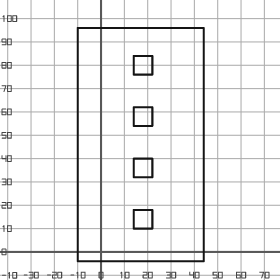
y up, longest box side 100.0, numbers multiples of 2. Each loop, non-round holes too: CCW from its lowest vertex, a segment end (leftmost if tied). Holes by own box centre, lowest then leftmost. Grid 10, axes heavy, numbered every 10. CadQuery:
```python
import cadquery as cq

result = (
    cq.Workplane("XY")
    .moveTo(-10.0, -4.0)
    .lineTo(44.0, -4.0)
    .lineTo(44.0, 96.0)
    .lineTo(-10.0, 96.0)
    .close()
    .moveTo(14.0, 10.0)
    .lineTo(22.0, 10.0)
    .lineTo(22.0, 18.0)
    .lineTo(14.0, 18.0)
    .close()
    .moveTo(14.0, 32.0)
    .lineTo(22.0, 32.0)
    .lineTo(22.0, 40.0)
    .lineTo(14.0, 40.0)
    .close()
    .moveTo(14.0, 54.0)
    .lineTo(22.0, 54.0)
    .lineTo(22.0, 62.0)
    .lineTo(14.0, 62.0)
    .close()
    .moveTo(14.0, 76.0)
    .lineTo(22.0, 76.0)
    .lineTo(22.0, 84.0)
    .lineTo(14.0, 84.0)
    .close()
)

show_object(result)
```